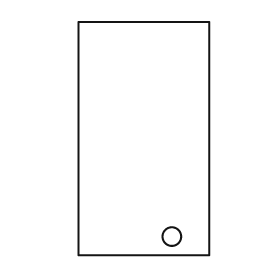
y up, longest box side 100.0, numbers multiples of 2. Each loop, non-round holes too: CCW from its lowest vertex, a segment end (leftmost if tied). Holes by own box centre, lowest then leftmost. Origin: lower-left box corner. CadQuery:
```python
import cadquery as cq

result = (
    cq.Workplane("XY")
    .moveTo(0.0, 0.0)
    .lineTo(56.0, 0.0)
    .lineTo(56.0, 100.0)
    .lineTo(0.0, 100.0)
    .close()
    .moveTo(40.0, 8.0)
    .circle(4.0)
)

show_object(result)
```